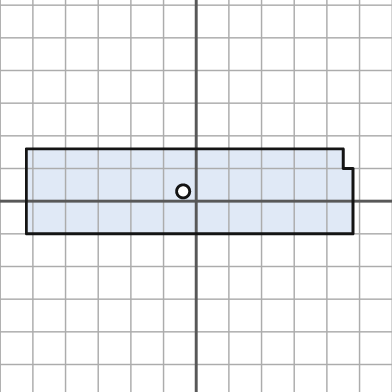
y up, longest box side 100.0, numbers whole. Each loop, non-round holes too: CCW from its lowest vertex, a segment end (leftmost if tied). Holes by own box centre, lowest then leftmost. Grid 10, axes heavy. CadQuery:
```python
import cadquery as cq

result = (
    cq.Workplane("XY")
    .moveTo(-52.0, -10.0)
    .lineTo(48.0, -10.0)
    .lineTo(48.0, 10.0)
    .lineTo(45.0, 10.0)
    .lineTo(45.0, 16.0)
    .lineTo(-52.0, 16.0)
    .close()
    .moveTo(-4.0, 3.0)
    .circle(2.0)
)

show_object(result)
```